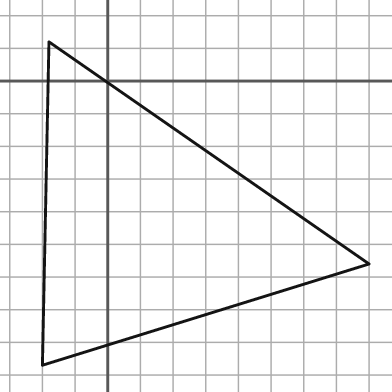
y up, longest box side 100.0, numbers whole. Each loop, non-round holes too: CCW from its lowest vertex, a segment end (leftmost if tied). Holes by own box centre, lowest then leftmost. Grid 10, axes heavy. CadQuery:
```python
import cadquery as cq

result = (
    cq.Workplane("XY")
    .moveTo(-20.0, -87.0)
    .lineTo(80.0, -56.0)
    .lineTo(-18.0, 12.0)
    .close()
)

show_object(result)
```